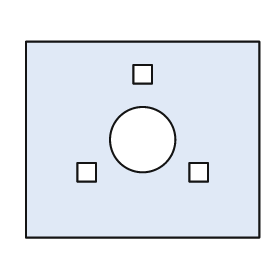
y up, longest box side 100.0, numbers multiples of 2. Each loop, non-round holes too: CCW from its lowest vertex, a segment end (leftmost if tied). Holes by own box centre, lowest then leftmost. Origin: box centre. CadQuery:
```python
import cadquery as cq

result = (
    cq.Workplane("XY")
    .moveTo(-50.0, -42.0)
    .lineTo(50.0, -42.0)
    .lineTo(50.0, 42.0)
    .lineTo(-50.0, 42.0)
    .close()
    .moveTo(-28.0, -18.0)
    .lineTo(-20.0, -18.0)
    .lineTo(-20.0, -10.0)
    .lineTo(-28.0, -10.0)
    .close()
    .moveTo(20.0, -18.0)
    .lineTo(28.0, -18.0)
    .lineTo(28.0, -10.0)
    .lineTo(20.0, -10.0)
    .close()
    .moveTo(0.0, 0.0)
    .circle(14.0)
    .moveTo(-4.0, 24.0)
    .lineTo(4.0, 24.0)
    .lineTo(4.0, 32.0)
    .lineTo(-4.0, 32.0)
    .close()
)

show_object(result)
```